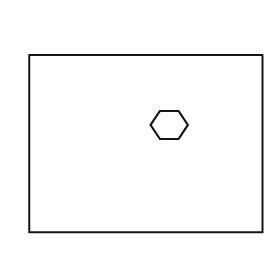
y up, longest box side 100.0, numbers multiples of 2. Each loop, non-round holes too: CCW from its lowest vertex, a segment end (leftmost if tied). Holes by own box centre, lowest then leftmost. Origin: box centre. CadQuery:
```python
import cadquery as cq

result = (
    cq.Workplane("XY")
    .moveTo(-50.0, -38.0)
    .lineTo(50.0, -38.0)
    .lineTo(50.0, 38.0)
    .lineTo(-50.0, 38.0)
    .close()
    .moveTo(6.0, 2.0)
    .lineTo(14.0, 2.0)
    .lineTo(18.0, 8.0)
    .lineTo(14.0, 14.0)
    .lineTo(6.0, 14.0)
    .lineTo(2.0, 8.0)
    .close()
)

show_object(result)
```